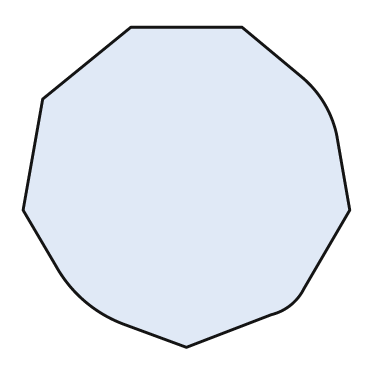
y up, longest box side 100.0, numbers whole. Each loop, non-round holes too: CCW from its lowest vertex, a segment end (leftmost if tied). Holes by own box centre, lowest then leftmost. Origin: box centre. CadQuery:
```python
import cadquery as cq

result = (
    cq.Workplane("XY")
    .moveTo(0.0, -49.0)
    .lineTo(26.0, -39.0)
    .threePointArc((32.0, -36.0), (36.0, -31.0))
    .lineTo(50.0, -7.0)
    .lineTo(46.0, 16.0)
    .threePointArc((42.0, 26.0), (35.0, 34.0))
    .lineTo(17.0, 49.0)
    .lineTo(-17.0, 49.0)
    .lineTo(-44.0, 27.0)
    .lineTo(-50.0, -7.0)
    .lineTo(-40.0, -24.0)
    .threePointArc((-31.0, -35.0), (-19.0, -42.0))
    .close()
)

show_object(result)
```